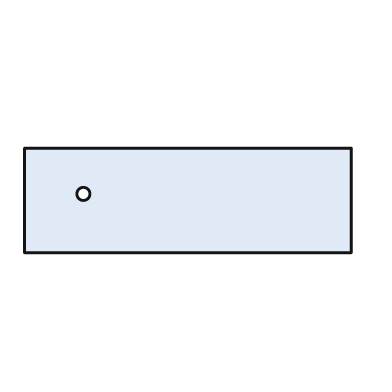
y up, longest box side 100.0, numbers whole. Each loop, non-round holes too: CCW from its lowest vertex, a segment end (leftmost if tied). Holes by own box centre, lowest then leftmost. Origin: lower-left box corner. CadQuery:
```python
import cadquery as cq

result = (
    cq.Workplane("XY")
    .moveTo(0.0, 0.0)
    .lineTo(100.0, 0.0)
    .lineTo(100.0, 32.0)
    .lineTo(0.0, 32.0)
    .close()
    .moveTo(18.0, 18.0)
    .circle(2.0)
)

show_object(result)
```